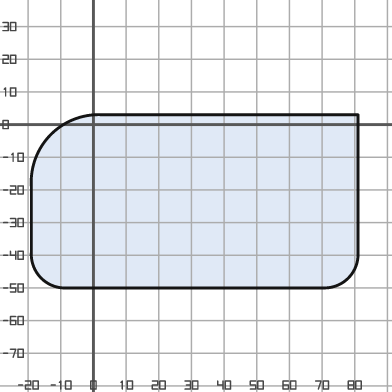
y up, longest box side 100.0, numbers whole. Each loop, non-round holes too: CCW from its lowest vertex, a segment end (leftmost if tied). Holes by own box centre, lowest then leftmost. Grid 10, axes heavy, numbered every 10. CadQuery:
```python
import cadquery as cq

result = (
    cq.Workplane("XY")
    .moveTo(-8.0, -50.0)
    .lineTo(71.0, -50.0)
    .threePointArc((78.0, -47.0), (81.0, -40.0))
    .lineTo(81.0, 3.0)
    .lineTo(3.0, 3.0)
    .threePointArc((-13.0, -3.0), (-19.0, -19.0))
    .lineTo(-19.0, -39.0)
    .threePointArc((-16.0, -47.0), (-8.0, -50.0))
    .close()
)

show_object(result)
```